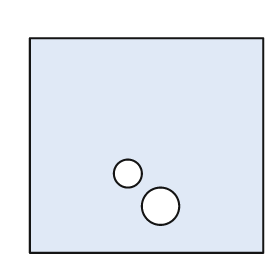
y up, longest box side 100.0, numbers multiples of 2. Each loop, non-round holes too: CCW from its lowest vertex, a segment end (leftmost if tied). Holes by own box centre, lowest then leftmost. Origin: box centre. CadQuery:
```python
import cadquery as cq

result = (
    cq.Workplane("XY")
    .moveTo(-50.0, -46.0)
    .lineTo(50.0, -46.0)
    .lineTo(50.0, 46.0)
    .lineTo(-50.0, 46.0)
    .close()
    .moveTo(6.0, -26.0)
    .circle(8.0)
    .moveTo(-8.0, -12.0)
    .circle(6.0)
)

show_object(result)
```